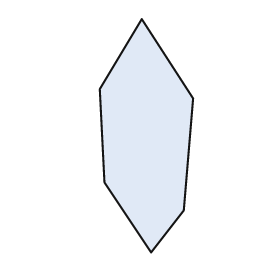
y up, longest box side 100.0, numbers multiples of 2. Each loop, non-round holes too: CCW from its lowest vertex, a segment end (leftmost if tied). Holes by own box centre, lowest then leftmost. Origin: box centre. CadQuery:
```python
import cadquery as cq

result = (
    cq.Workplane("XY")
    .moveTo(2.0, -50.0)
    .lineTo(16.0, -32.0)
    .lineTo(20.0, 16.0)
    .lineTo(-2.0, 50.0)
    .lineTo(-20.0, 20.0)
    .lineTo(-18.0, -20.0)
    .close()
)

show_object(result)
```